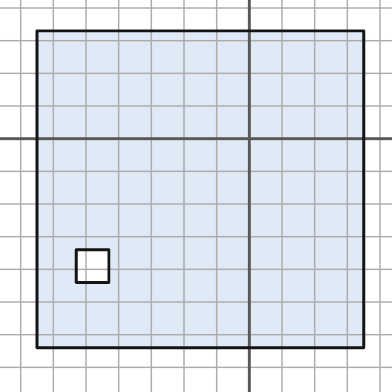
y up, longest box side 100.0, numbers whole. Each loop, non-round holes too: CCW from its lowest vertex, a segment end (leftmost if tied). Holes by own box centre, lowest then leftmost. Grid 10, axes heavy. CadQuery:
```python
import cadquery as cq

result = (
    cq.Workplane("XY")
    .moveTo(-65.0, -64.0)
    .lineTo(35.0, -64.0)
    .lineTo(35.0, 33.0)
    .lineTo(-65.0, 33.0)
    .close()
    .moveTo(-53.0, -44.0)
    .lineTo(-43.0, -44.0)
    .lineTo(-43.0, -34.0)
    .lineTo(-53.0, -34.0)
    .close()
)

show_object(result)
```